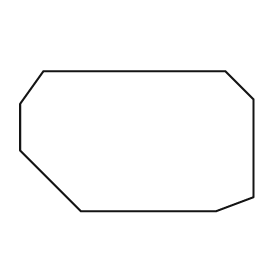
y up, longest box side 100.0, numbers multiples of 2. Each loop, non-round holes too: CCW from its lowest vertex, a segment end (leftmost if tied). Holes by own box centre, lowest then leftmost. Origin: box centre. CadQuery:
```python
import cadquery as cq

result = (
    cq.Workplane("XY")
    .moveTo(-24.0, -30.0)
    .lineTo(34.0, -30.0)
    .lineTo(50.0, -24.0)
    .lineTo(50.0, 18.0)
    .lineTo(38.0, 30.0)
    .lineTo(-40.0, 30.0)
    .lineTo(-50.0, 16.0)
    .lineTo(-50.0, -4.0)
    .close()
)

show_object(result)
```